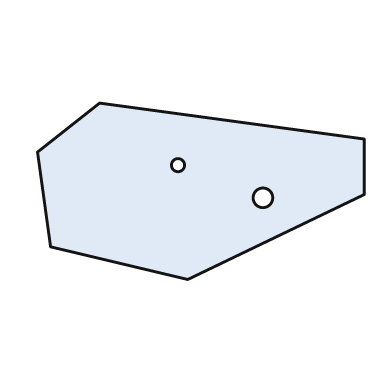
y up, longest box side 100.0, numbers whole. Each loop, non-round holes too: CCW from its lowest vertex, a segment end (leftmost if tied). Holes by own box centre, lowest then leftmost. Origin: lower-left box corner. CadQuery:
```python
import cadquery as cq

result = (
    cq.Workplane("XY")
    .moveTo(46.0, 0.0)
    .lineTo(100.0, 26.0)
    .lineTo(100.0, 43.0)
    .lineTo(19.0, 54.0)
    .lineTo(0.0, 39.0)
    .lineTo(4.0, 10.0)
    .close()
    .moveTo(69.0, 25.0)
    .circle(3.0)
    .moveTo(43.0, 35.0)
    .circle(2.0)
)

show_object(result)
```